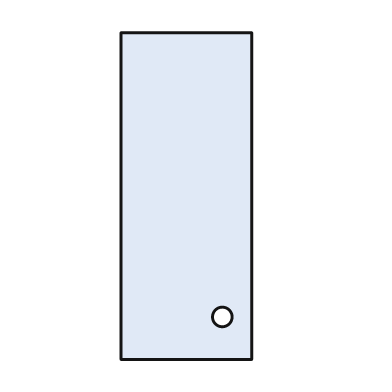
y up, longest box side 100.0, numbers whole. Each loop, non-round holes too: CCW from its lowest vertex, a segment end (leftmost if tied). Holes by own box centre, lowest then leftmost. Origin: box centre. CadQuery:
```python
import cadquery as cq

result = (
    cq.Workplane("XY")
    .moveTo(-20.0, -50.0)
    .lineTo(20.0, -50.0)
    .lineTo(20.0, 50.0)
    .lineTo(-20.0, 50.0)
    .close()
    .moveTo(11.0, -37.0)
    .circle(3.0)
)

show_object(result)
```